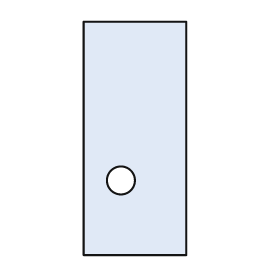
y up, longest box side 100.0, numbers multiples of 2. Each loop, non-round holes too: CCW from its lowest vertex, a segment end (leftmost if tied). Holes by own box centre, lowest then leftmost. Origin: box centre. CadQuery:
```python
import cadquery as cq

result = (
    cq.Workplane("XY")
    .moveTo(-22.0, -50.0)
    .lineTo(22.0, -50.0)
    .lineTo(22.0, 50.0)
    .lineTo(-22.0, 50.0)
    .close()
    .moveTo(-6.0, -18.0)
    .circle(6.0)
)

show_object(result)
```